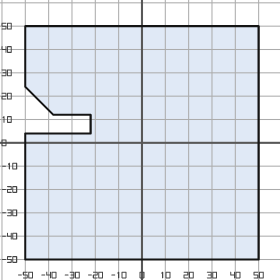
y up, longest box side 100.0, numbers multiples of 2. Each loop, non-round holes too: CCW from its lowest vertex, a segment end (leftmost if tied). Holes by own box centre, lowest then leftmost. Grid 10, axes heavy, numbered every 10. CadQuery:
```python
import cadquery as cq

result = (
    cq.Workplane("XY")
    .moveTo(-50.0, -50.0)
    .lineTo(50.0, -50.0)
    .lineTo(50.0, 50.0)
    .lineTo(-50.0, 50.0)
    .lineTo(-50.0, 24.0)
    .lineTo(-38.0, 12.0)
    .lineTo(-22.0, 12.0)
    .lineTo(-22.0, 4.0)
    .lineTo(-50.0, 4.0)
    .close()
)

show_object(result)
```